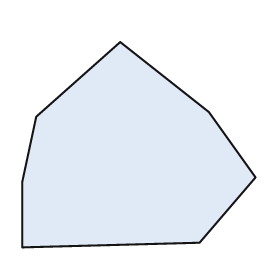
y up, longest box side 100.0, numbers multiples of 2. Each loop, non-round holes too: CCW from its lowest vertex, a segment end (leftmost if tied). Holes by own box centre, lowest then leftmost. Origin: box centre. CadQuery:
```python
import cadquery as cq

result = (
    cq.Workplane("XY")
    .moveTo(-50.0, -44.0)
    .lineTo(26.0, -42.0)
    .lineTo(50.0, -14.0)
    .lineTo(30.0, 14.0)
    .lineTo(-8.0, 44.0)
    .lineTo(-44.0, 12.0)
    .lineTo(-50.0, -16.0)
    .close()
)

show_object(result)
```